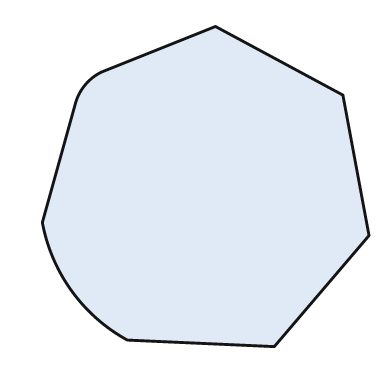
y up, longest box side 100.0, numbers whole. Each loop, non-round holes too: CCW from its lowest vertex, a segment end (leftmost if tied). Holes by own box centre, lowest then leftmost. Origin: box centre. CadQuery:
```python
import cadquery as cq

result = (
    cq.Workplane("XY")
    .moveTo(21.0, -49.0)
    .lineTo(50.0, -15.0)
    .lineTo(42.0, 28.0)
    .lineTo(3.0, 49.0)
    .lineTo(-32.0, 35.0)
    .threePointArc((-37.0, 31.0), (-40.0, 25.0))
    .lineTo(-50.0, -11.0)
    .threePointArc((-41.0, -32.0), (-24.0, -47.0))
    .close()
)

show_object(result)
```